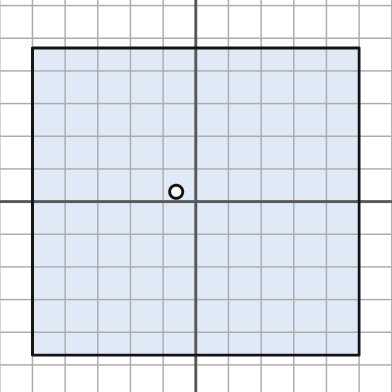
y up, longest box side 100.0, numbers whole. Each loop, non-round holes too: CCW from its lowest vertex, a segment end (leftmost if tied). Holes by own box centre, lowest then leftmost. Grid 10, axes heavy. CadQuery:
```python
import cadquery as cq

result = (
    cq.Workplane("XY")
    .moveTo(-50.0, -47.0)
    .lineTo(50.0, -47.0)
    .lineTo(50.0, 47.0)
    .lineTo(-50.0, 47.0)
    .close()
    .moveTo(-6.0, 3.0)
    .circle(2.0)
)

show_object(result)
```